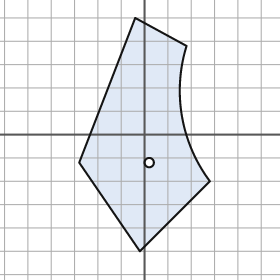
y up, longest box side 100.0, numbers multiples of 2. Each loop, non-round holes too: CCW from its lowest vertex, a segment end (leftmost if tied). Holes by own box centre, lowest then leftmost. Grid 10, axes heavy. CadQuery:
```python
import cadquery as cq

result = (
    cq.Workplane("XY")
    .moveTo(-2.0, -50.0)
    .lineTo(28.0, -20.0)
    .threePointArc((16.0, 8.0), (18.0, 38.0))
    .lineTo(-4.0, 50.0)
    .lineTo(-28.0, -12.0)
    .close()
    .moveTo(2.0, -12.0)
    .circle(2.0)
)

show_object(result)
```